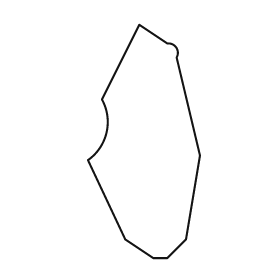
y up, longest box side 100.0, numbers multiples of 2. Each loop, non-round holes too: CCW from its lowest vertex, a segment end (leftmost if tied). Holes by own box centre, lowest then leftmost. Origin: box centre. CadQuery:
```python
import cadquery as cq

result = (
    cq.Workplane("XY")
    .moveTo(4.0, -50.0)
    .lineTo(10.0, -50.0)
    .lineTo(18.0, -42.0)
    .lineTo(24.0, -6.0)
    .lineTo(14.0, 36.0)
    .threePointArc((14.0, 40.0), (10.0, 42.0))
    .lineTo(-2.0, 50.0)
    .lineTo(-18.0, 18.0)
    .threePointArc((-16.0, 4.0), (-24.0, -8.0))
    .lineTo(-8.0, -42.0)
    .close()
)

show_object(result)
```